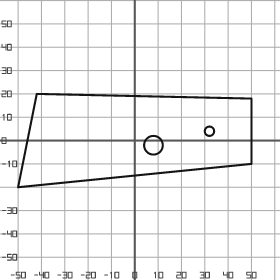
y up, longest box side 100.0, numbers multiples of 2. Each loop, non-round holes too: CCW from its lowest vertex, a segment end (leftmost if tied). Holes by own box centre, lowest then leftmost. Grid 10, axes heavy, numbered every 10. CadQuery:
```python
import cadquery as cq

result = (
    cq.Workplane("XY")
    .moveTo(-50.0, -20.0)
    .lineTo(50.0, -10.0)
    .lineTo(50.0, 18.0)
    .lineTo(-42.0, 20.0)
    .close()
    .moveTo(8.0, -2.0)
    .circle(4.0)
    .moveTo(32.0, 4.0)
    .circle(2.0)
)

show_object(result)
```